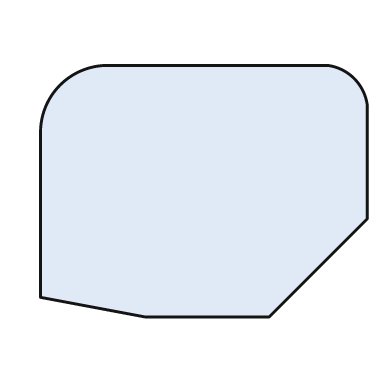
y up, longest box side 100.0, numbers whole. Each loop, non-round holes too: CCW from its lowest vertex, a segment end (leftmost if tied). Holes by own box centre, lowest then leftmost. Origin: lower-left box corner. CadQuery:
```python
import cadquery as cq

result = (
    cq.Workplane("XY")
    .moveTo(32.0, 0.0)
    .lineTo(70.0, 0.0)
    .lineTo(100.0, 30.0)
    .lineTo(100.0, 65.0)
    .threePointArc((96.0, 73.0), (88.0, 77.0))
    .lineTo(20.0, 77.0)
    .threePointArc((6.0, 71.0), (0.0, 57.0))
    .lineTo(0.0, 6.0)
    .close()
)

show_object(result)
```